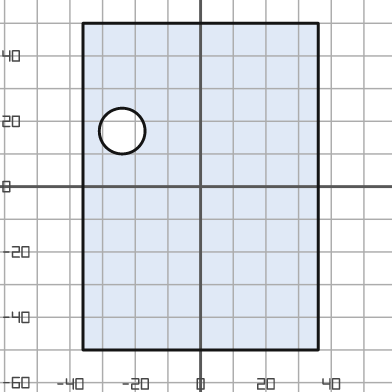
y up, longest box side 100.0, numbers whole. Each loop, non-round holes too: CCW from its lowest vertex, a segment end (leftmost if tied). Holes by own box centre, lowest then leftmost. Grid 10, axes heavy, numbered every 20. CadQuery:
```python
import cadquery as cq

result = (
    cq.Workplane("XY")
    .moveTo(-36.0, -50.0)
    .lineTo(36.0, -50.0)
    .lineTo(36.0, 50.0)
    .lineTo(-36.0, 50.0)
    .close()
    .moveTo(-24.0, 17.0)
    .circle(7.0)
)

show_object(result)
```